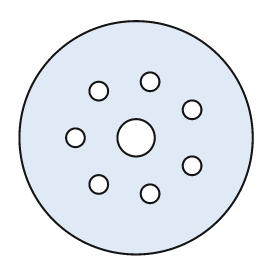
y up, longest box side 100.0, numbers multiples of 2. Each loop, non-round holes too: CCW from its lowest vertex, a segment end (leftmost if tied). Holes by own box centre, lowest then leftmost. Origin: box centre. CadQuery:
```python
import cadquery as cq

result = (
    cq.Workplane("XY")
    .moveTo(0.0, 0.0)
    .circle(50.0)
    .moveTo(6.0, -24.0)
    .circle(4.0)
    .moveTo(-16.0, -20.0)
    .circle(4.0)
    .moveTo(24.0, -12.0)
    .circle(4.0)
    .moveTo(-26.0, 0.0)
    .circle(4.0)
    .moveTo(0.0, 0.0)
    .circle(8.0)
    .moveTo(24.0, 12.0)
    .circle(4.0)
    .moveTo(-16.0, 20.0)
    .circle(4.0)
    .moveTo(6.0, 24.0)
    .circle(4.0)
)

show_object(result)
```